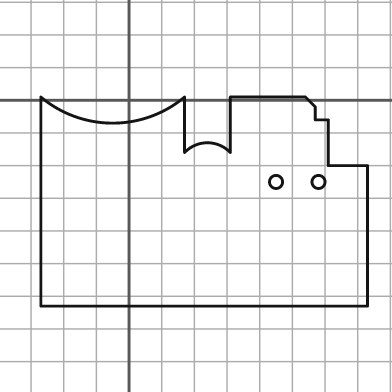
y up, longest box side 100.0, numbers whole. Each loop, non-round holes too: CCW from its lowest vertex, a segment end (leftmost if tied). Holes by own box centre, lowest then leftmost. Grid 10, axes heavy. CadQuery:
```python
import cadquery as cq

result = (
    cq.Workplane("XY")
    .moveTo(-27.0, -63.0)
    .lineTo(73.0, -63.0)
    .lineTo(73.0, -20.0)
    .lineTo(61.0, -20.0)
    .lineTo(61.0, -6.0)
    .lineTo(57.0, -6.0)
    .lineTo(57.0, -2.0)
    .lineTo(54.0, 1.0)
    .lineTo(31.0, 1.0)
    .lineTo(31.0, -16.0)
    .threePointArc((24.0, -13.0), (17.0, -16.0))
    .lineTo(17.0, 1.0)
    .threePointArc((-5.0, -7.0), (-27.0, 1.0))
    .close()
    .moveTo(45.0, -25.0)
    .circle(2.0)
    .moveTo(58.0, -25.0)
    .circle(2.0)
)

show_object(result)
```